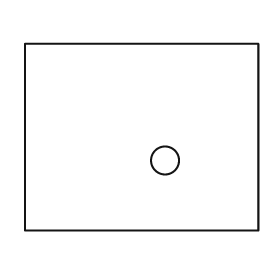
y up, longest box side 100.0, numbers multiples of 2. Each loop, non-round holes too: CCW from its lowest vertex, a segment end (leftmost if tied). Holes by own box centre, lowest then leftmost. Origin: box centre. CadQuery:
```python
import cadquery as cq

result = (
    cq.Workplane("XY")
    .moveTo(-50.0, -40.0)
    .lineTo(50.0, -40.0)
    .lineTo(50.0, 40.0)
    .lineTo(-50.0, 40.0)
    .close()
    .moveTo(10.0, -10.0)
    .circle(6.0)
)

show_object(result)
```